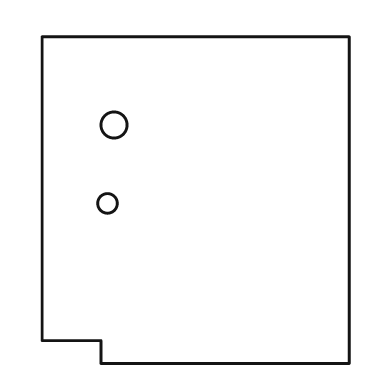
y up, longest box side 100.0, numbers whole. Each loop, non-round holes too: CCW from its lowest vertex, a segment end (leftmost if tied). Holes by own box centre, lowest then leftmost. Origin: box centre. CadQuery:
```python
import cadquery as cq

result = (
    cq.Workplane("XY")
    .moveTo(-29.0, -50.0)
    .lineTo(47.0, -50.0)
    .lineTo(47.0, 50.0)
    .lineTo(-47.0, 50.0)
    .lineTo(-47.0, -43.0)
    .lineTo(-29.0, -43.0)
    .close()
    .moveTo(-27.0, -1.0)
    .circle(3.0)
    .moveTo(-25.0, 23.0)
    .circle(4.0)
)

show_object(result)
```